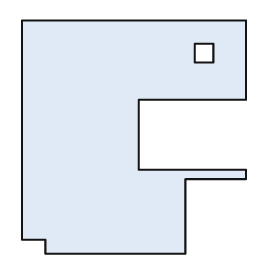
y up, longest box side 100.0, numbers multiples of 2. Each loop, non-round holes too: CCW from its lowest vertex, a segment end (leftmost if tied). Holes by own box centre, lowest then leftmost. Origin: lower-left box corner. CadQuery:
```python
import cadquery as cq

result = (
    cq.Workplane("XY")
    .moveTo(10.0, 0.0)
    .lineTo(70.0, 0.0)
    .lineTo(70.0, 32.0)
    .lineTo(96.0, 32.0)
    .lineTo(96.0, 36.0)
    .lineTo(50.0, 36.0)
    .lineTo(50.0, 66.0)
    .lineTo(96.0, 66.0)
    .lineTo(96.0, 100.0)
    .lineTo(0.0, 100.0)
    .lineTo(0.0, 6.0)
    .lineTo(10.0, 6.0)
    .close()
    .moveTo(74.0, 82.0)
    .lineTo(82.0, 82.0)
    .lineTo(82.0, 90.0)
    .lineTo(74.0, 90.0)
    .close()
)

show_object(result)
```